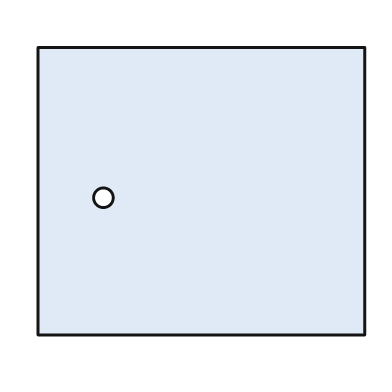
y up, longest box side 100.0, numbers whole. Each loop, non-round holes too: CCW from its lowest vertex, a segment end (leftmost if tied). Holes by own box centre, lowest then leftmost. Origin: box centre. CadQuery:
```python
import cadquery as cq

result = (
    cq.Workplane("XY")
    .moveTo(-50.0, -44.0)
    .lineTo(50.0, -44.0)
    .lineTo(50.0, 44.0)
    .lineTo(-50.0, 44.0)
    .close()
    .moveTo(-30.0, -2.0)
    .circle(3.0)
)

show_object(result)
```